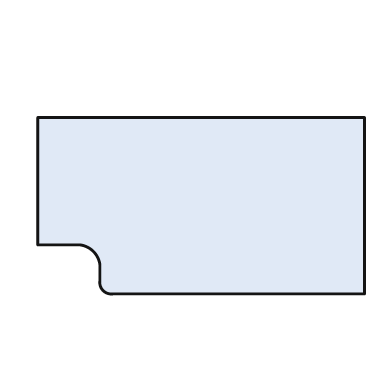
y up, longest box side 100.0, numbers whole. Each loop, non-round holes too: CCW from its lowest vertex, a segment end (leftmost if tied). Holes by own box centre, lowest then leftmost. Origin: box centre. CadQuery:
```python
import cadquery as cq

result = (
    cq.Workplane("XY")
    .moveTo(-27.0, -27.0)
    .lineTo(50.0, -27.0)
    .lineTo(50.0, 27.0)
    .lineTo(-50.0, 27.0)
    .lineTo(-50.0, -12.0)
    .lineTo(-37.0, -12.0)
    .threePointArc((-33.0, -14.0), (-31.0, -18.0))
    .lineTo(-31.0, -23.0)
    .threePointArc((-30.0, -26.0), (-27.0, -27.0))
    .close()
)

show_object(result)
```